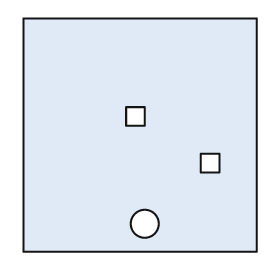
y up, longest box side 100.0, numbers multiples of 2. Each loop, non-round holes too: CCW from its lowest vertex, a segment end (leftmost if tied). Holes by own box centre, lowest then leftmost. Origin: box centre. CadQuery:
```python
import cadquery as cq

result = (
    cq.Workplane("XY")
    .moveTo(-50.0, -50.0)
    .lineTo(50.0, -50.0)
    .lineTo(50.0, 50.0)
    .lineTo(-50.0, 50.0)
    .close()
    .moveTo(2.0, -38.0)
    .circle(6.0)
    .moveTo(26.0, -16.0)
    .lineTo(34.0, -16.0)
    .lineTo(34.0, -8.0)
    .lineTo(26.0, -8.0)
    .close()
    .moveTo(-6.0, 4.0)
    .lineTo(2.0, 4.0)
    .lineTo(2.0, 12.0)
    .lineTo(-6.0, 12.0)
    .close()
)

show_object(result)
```